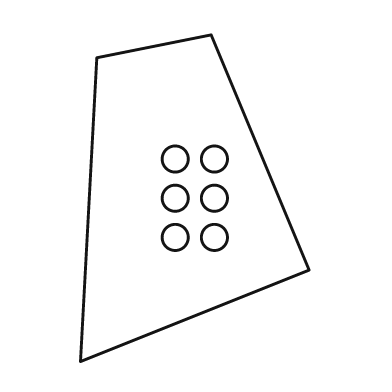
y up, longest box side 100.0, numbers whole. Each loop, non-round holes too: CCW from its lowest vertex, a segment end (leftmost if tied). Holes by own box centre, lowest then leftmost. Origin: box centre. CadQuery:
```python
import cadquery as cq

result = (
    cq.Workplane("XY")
    .moveTo(-35.0, -50.0)
    .lineTo(35.0, -22.0)
    .lineTo(5.0, 50.0)
    .lineTo(-30.0, 43.0)
    .close()
    .moveTo(-6.0, -12.0)
    .circle(4.0)
    .moveTo(6.0, -12.0)
    .circle(4.0)
    .moveTo(-6.0, 0.0)
    .circle(4.0)
    .moveTo(6.0, 0.0)
    .circle(4.0)
    .moveTo(-6.0, 12.0)
    .circle(4.0)
    .moveTo(6.0, 12.0)
    .circle(4.0)
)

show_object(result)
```